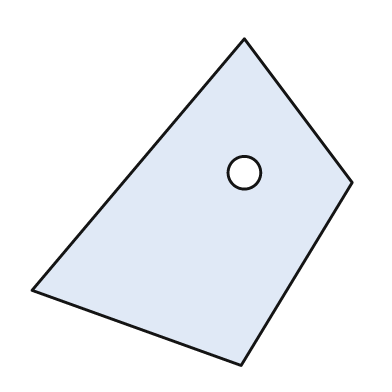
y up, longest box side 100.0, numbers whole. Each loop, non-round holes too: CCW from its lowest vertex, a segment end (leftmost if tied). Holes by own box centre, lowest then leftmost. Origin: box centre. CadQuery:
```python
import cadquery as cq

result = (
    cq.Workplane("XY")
    .moveTo(15.0, -50.0)
    .lineTo(49.0, 6.0)
    .lineTo(16.0, 50.0)
    .lineTo(-49.0, -27.0)
    .close()
    .moveTo(16.0, 9.0)
    .circle(5.0)
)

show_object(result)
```